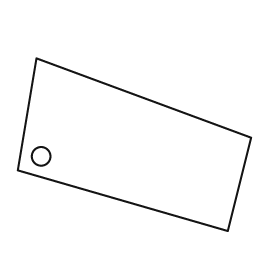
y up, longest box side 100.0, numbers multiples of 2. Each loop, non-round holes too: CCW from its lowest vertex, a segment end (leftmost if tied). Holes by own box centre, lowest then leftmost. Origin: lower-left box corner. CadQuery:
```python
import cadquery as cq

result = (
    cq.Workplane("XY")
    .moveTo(90.0, 0.0)
    .lineTo(100.0, 40.0)
    .lineTo(8.0, 74.0)
    .lineTo(0.0, 26.0)
    .close()
    .moveTo(10.0, 32.0)
    .circle(4.0)
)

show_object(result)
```